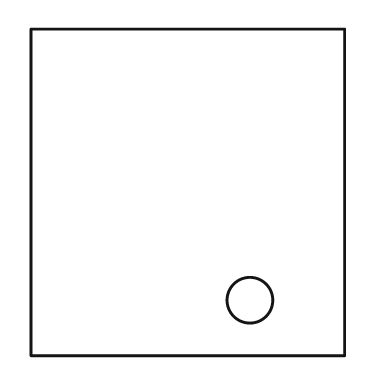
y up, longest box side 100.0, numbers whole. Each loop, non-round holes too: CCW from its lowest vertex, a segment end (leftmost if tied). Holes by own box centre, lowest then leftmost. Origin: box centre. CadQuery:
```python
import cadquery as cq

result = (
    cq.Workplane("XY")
    .moveTo(-48.0, -50.0)
    .lineTo(48.0, -50.0)
    .lineTo(48.0, 50.0)
    .lineTo(-48.0, 50.0)
    .close()
    .moveTo(19.0, -33.0)
    .circle(7.0)
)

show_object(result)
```